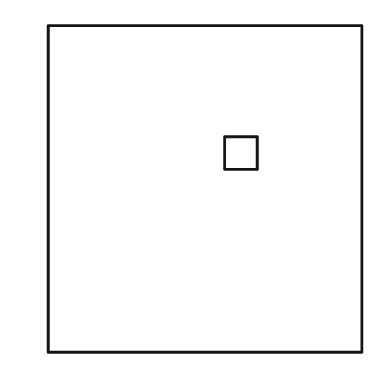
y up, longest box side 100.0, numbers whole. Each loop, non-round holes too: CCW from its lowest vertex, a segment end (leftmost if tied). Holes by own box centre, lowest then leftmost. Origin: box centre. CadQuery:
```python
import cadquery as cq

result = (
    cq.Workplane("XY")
    .moveTo(-48.0, -50.0)
    .lineTo(48.0, -50.0)
    .lineTo(48.0, 50.0)
    .lineTo(-48.0, 50.0)
    .close()
    .moveTo(6.0, 6.0)
    .lineTo(16.0, 6.0)
    .lineTo(16.0, 16.0)
    .lineTo(6.0, 16.0)
    .close()
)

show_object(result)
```